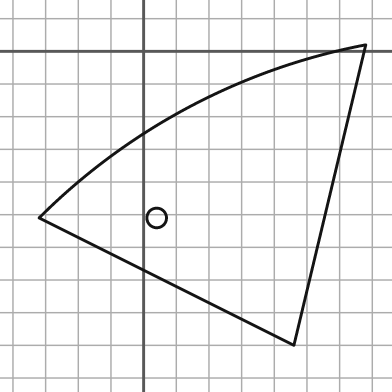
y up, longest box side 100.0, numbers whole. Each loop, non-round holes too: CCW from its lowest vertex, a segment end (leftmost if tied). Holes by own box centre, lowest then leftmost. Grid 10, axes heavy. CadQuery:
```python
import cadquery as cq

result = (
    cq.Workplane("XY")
    .moveTo(46.0, -90.0)
    .lineTo(68.0, 2.0)
    .threePointArc((14.0, -17.0), (-32.0, -51.0))
    .close()
    .moveTo(4.0, -51.0)
    .circle(3.0)
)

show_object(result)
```